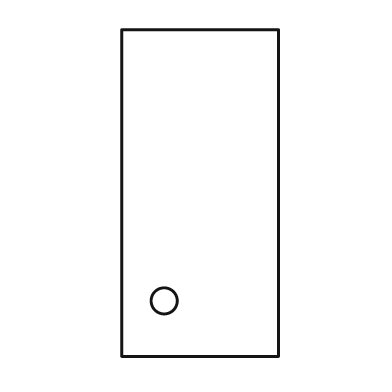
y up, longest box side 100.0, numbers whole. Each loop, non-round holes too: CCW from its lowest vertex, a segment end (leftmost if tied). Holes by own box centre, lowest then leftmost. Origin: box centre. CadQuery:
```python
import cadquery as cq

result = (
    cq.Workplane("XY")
    .moveTo(-24.0, -50.0)
    .lineTo(24.0, -50.0)
    .lineTo(24.0, 50.0)
    .lineTo(-24.0, 50.0)
    .close()
    .moveTo(-11.0, -33.0)
    .circle(4.0)
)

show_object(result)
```